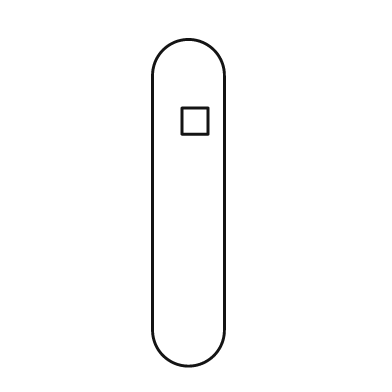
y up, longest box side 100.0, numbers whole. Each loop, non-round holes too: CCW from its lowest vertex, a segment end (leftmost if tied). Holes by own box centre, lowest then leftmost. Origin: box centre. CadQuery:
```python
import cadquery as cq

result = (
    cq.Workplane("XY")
    .moveTo(-11.0, -39.0)
    .threePointArc((0.0, -50.0), (11.0, -39.0))
    .lineTo(11.0, 39.0)
    .threePointArc((0.0, 50.0), (-11.0, 39.0))
    .close()
    .moveTo(-2.0, 21.0)
    .lineTo(6.0, 21.0)
    .lineTo(6.0, 29.0)
    .lineTo(-2.0, 29.0)
    .close()
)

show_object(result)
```